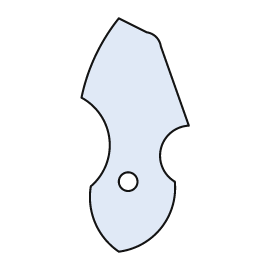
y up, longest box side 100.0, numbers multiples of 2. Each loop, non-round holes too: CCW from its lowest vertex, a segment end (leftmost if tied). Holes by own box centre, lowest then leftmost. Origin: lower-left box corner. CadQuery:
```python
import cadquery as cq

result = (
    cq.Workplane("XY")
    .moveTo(16.0, 0.0)
    .threePointArc((34.0, 10.0), (40.0, 30.0))
    .threePointArc((34.0, 44.0), (46.0, 54.0))
    .lineTo(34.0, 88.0)
    .threePointArc((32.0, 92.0), (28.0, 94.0))
    .lineTo(16.0, 100.0)
    .threePointArc((6.0, 84.0), (0.0, 66.0))
    .threePointArc((12.0, 48.0), (4.0, 28.0))
    .threePointArc((6.0, 12.0), (16.0, 0.0))
    .close()
    .moveTo(20.0, 30.0)
    .circle(4.0)
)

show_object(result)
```